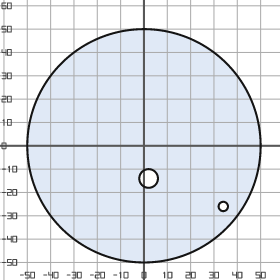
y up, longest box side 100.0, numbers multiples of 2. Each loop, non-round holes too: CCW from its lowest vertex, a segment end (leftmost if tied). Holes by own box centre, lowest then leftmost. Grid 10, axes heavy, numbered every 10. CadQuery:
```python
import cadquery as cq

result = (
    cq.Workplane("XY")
    .moveTo(0.0, 0.0)
    .circle(50.0)
    .moveTo(34.0, -26.0)
    .circle(2.0)
    .moveTo(2.0, -14.0)
    .circle(4.0)
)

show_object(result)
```